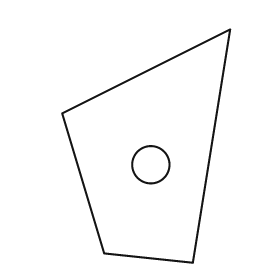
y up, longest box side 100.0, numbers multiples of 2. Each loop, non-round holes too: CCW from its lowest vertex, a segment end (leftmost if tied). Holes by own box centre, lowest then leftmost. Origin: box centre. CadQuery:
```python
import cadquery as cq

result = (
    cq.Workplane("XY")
    .moveTo(20.0, -50.0)
    .lineTo(36.0, 50.0)
    .lineTo(-36.0, 14.0)
    .lineTo(-18.0, -46.0)
    .close()
    .moveTo(2.0, -8.0)
    .circle(8.0)
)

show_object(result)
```